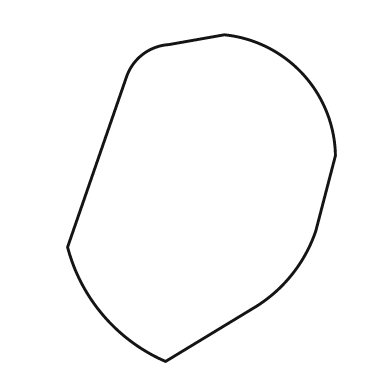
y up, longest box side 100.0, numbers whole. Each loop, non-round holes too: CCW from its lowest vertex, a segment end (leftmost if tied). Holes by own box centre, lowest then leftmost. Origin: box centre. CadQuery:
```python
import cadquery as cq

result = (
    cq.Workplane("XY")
    .moveTo(-11.0, -50.0)
    .lineTo(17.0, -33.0)
    .threePointArc((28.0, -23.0), (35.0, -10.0))
    .lineTo(41.0, 13.0)
    .threePointArc((31.0, 38.0), (7.0, 50.0))
    .lineTo(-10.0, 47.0)
    .threePointArc((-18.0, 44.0), (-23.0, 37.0))
    .lineTo(-41.0, -15.0)
    .threePointArc((-30.0, -36.0), (-11.0, -50.0))
    .close()
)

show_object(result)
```